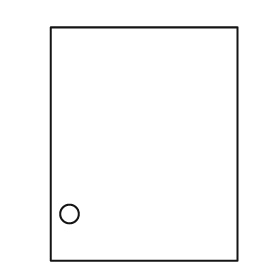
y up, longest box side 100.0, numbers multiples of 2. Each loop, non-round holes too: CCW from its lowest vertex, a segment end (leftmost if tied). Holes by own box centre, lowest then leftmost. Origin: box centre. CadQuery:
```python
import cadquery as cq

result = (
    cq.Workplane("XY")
    .moveTo(-40.0, -50.0)
    .lineTo(40.0, -50.0)
    .lineTo(40.0, 50.0)
    .lineTo(-40.0, 50.0)
    .close()
    .moveTo(-32.0, -30.0)
    .circle(4.0)
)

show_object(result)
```